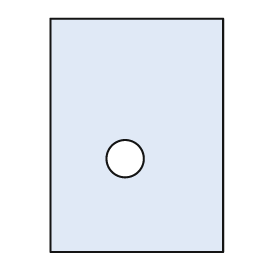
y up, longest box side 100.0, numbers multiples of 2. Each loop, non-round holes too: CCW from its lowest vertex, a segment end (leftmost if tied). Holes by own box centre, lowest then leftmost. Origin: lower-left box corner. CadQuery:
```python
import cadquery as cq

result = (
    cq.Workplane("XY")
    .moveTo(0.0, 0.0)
    .lineTo(74.0, 0.0)
    .lineTo(74.0, 100.0)
    .lineTo(0.0, 100.0)
    .close()
    .moveTo(32.0, 40.0)
    .circle(8.0)
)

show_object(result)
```